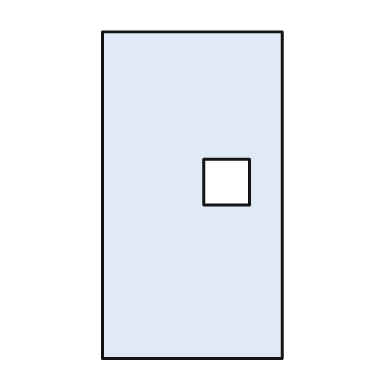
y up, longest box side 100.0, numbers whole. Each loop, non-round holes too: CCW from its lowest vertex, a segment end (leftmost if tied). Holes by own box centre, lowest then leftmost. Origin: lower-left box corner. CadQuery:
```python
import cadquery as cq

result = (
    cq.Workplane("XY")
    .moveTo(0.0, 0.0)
    .lineTo(55.0, 0.0)
    .lineTo(55.0, 100.0)
    .lineTo(0.0, 100.0)
    .close()
    .moveTo(31.0, 47.0)
    .lineTo(45.0, 47.0)
    .lineTo(45.0, 61.0)
    .lineTo(31.0, 61.0)
    .close()
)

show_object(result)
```